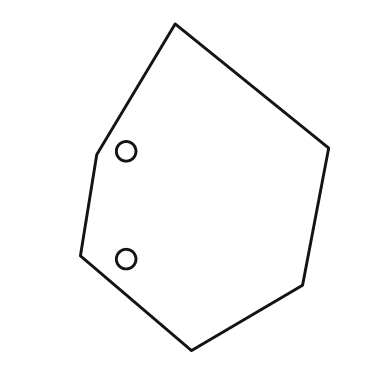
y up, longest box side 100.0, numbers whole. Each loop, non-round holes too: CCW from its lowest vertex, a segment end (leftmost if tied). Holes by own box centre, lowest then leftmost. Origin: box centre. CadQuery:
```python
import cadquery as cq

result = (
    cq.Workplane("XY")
    .moveTo(-4.0, -50.0)
    .lineTo(30.0, -30.0)
    .lineTo(38.0, 12.0)
    .lineTo(-9.0, 50.0)
    .lineTo(-33.0, 10.0)
    .lineTo(-38.0, -21.0)
    .close()
    .moveTo(-24.0, -22.0)
    .circle(3.0)
    .moveTo(-24.0, 11.0)
    .circle(3.0)
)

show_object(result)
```